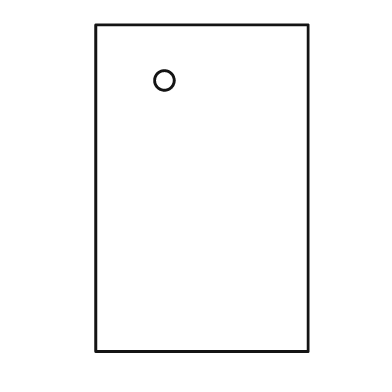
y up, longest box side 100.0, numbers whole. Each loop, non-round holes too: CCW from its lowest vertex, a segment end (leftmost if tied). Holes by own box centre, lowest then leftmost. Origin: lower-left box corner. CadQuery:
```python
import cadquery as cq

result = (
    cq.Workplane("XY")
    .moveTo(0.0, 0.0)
    .lineTo(65.0, 0.0)
    .lineTo(65.0, 100.0)
    .lineTo(0.0, 100.0)
    .close()
    .moveTo(21.0, 83.0)
    .circle(3.0)
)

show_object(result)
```